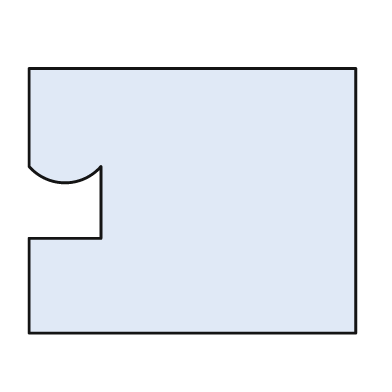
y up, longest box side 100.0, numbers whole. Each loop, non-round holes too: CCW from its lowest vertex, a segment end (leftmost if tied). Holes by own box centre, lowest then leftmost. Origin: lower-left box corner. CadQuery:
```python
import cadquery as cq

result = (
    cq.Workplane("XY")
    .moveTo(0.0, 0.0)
    .lineTo(100.0, 0.0)
    .lineTo(100.0, 81.0)
    .lineTo(0.0, 81.0)
    .lineTo(0.0, 51.0)
    .threePointArc((11.0, 46.0), (22.0, 51.0))
    .lineTo(22.0, 29.0)
    .lineTo(0.0, 29.0)
    .close()
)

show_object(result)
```